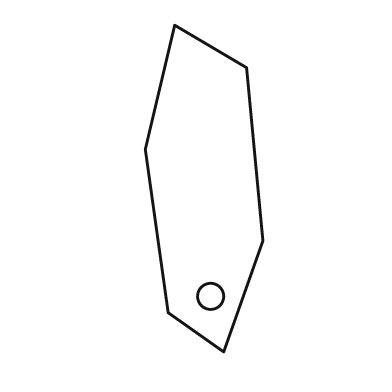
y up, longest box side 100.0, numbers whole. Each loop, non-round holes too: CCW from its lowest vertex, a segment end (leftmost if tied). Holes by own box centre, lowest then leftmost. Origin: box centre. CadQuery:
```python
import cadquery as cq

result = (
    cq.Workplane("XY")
    .moveTo(6.0, -50.0)
    .lineTo(18.0, -16.0)
    .lineTo(13.0, 37.0)
    .lineTo(-9.0, 50.0)
    .lineTo(-18.0, 12.0)
    .lineTo(-11.0, -38.0)
    .close()
    .moveTo(2.0, -33.0)
    .circle(4.0)
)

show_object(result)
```